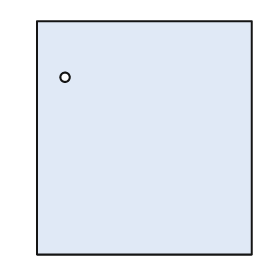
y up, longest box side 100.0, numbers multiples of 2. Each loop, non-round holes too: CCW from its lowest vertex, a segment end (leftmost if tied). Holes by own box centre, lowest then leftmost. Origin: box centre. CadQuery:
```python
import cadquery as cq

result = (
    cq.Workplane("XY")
    .moveTo(-46.0, -50.0)
    .lineTo(46.0, -50.0)
    .lineTo(46.0, 50.0)
    .lineTo(-46.0, 50.0)
    .close()
    .moveTo(-34.0, 26.0)
    .circle(2.0)
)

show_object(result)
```